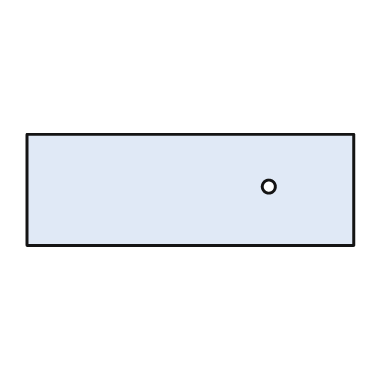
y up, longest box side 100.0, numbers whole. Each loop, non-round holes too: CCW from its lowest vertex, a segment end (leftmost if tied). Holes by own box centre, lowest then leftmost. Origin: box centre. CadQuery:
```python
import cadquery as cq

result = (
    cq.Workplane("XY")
    .moveTo(-50.0, -17.0)
    .lineTo(50.0, -17.0)
    .lineTo(50.0, 17.0)
    .lineTo(-50.0, 17.0)
    .close()
    .moveTo(24.0, 1.0)
    .circle(2.0)
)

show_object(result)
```